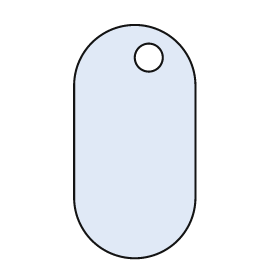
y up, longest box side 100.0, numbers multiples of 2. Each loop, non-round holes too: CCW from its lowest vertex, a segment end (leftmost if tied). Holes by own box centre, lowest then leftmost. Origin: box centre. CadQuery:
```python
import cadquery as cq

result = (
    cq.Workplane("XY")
    .moveTo(-26.0, -24.0)
    .threePointArc((0.0, -50.0), (26.0, -24.0))
    .lineTo(26.0, 24.0)
    .threePointArc((0.0, 50.0), (-26.0, 24.0))
    .close()
    .moveTo(6.0, 36.0)
    .circle(6.0)
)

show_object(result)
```